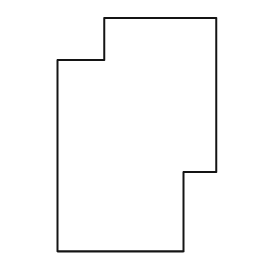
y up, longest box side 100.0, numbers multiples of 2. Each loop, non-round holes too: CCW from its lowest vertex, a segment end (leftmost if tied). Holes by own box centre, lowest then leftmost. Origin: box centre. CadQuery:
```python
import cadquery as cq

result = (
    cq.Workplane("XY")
    .moveTo(-34.0, -50.0)
    .lineTo(20.0, -50.0)
    .lineTo(20.0, -16.0)
    .lineTo(34.0, -16.0)
    .lineTo(34.0, 50.0)
    .lineTo(-14.0, 50.0)
    .lineTo(-14.0, 32.0)
    .lineTo(-34.0, 32.0)
    .close()
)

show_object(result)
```